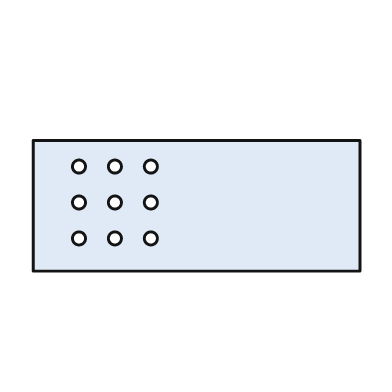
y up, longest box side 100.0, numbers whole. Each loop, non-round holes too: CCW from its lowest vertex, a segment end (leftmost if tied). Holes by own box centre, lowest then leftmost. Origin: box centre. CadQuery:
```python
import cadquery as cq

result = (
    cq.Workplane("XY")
    .moveTo(-50.0, -20.0)
    .lineTo(50.0, -20.0)
    .lineTo(50.0, 20.0)
    .lineTo(-50.0, 20.0)
    .close()
    .moveTo(-36.0, -10.0)
    .circle(2.0)
    .moveTo(-25.0, -10.0)
    .circle(2.0)
    .moveTo(-14.0, -10.0)
    .circle(2.0)
    .moveTo(-36.0, 1.0)
    .circle(2.0)
    .moveTo(-25.0, 1.0)
    .circle(2.0)
    .moveTo(-14.0, 1.0)
    .circle(2.0)
    .moveTo(-36.0, 12.0)
    .circle(2.0)
    .moveTo(-25.0, 12.0)
    .circle(2.0)
    .moveTo(-14.0, 12.0)
    .circle(2.0)
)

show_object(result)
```